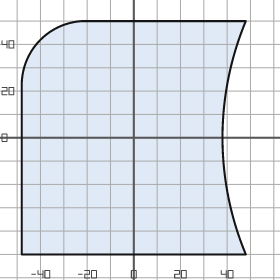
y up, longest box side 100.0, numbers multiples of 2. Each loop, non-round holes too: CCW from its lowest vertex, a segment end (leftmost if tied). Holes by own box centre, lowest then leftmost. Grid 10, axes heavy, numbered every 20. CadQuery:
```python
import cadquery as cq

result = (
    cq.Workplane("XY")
    .moveTo(-48.0, -50.0)
    .lineTo(48.0, -50.0)
    .threePointArc((38.0, 0.0), (48.0, 50.0))
    .lineTo(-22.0, 50.0)
    .threePointArc((-40.0, 42.0), (-48.0, 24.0))
    .close()
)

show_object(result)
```